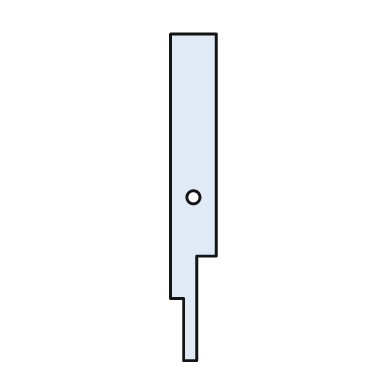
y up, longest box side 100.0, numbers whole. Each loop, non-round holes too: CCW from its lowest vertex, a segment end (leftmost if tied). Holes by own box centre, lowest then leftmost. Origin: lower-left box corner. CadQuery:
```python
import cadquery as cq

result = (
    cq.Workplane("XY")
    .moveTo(4.0, 0.0)
    .lineTo(8.0, 0.0)
    .lineTo(8.0, 32.0)
    .lineTo(14.0, 32.0)
    .lineTo(14.0, 100.0)
    .lineTo(0.0, 100.0)
    .lineTo(0.0, 19.0)
    .lineTo(4.0, 19.0)
    .close()
    .moveTo(7.0, 50.0)
    .circle(2.0)
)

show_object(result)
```